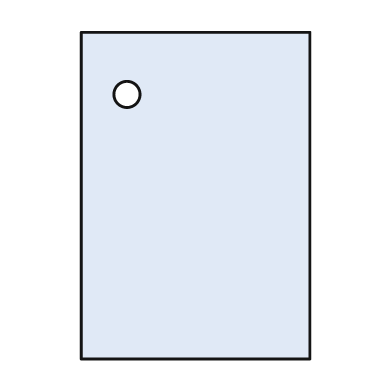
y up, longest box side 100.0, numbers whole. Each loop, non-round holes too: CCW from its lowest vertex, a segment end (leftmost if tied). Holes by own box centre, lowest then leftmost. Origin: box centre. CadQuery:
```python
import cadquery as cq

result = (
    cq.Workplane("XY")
    .moveTo(-35.0, -50.0)
    .lineTo(35.0, -50.0)
    .lineTo(35.0, 50.0)
    .lineTo(-35.0, 50.0)
    .close()
    .moveTo(-21.0, 31.0)
    .circle(4.0)
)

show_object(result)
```